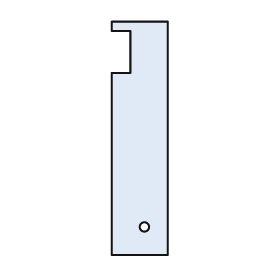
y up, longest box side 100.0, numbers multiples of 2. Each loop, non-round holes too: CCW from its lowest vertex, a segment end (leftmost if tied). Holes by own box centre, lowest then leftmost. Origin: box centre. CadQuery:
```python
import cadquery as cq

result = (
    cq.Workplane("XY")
    .moveTo(-12.0, -50.0)
    .lineTo(12.0, -50.0)
    .lineTo(12.0, 50.0)
    .lineTo(-12.0, 50.0)
    .lineTo(-12.0, 46.0)
    .lineTo(-4.0, 46.0)
    .lineTo(-4.0, 28.0)
    .lineTo(-12.0, 28.0)
    .close()
    .moveTo(2.0, -38.0)
    .circle(2.0)
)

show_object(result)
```